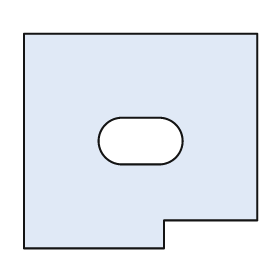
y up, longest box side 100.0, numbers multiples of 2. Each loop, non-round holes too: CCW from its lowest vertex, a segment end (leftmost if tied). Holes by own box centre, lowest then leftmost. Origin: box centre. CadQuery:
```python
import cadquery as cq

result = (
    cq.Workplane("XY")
    .moveTo(-50.0, -46.0)
    .lineTo(10.0, -46.0)
    .lineTo(10.0, -34.0)
    .lineTo(50.0, -34.0)
    .lineTo(50.0, 46.0)
    .lineTo(-50.0, 46.0)
    .close()
    .moveTo(-8.0, -10.0)
    .lineTo(8.0, -10.0)
    .threePointArc((18.0, 0.0), (8.0, 10.0))
    .lineTo(-8.0, 10.0)
    .threePointArc((-18.0, 0.0), (-8.0, -10.0))
    .close()
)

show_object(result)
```